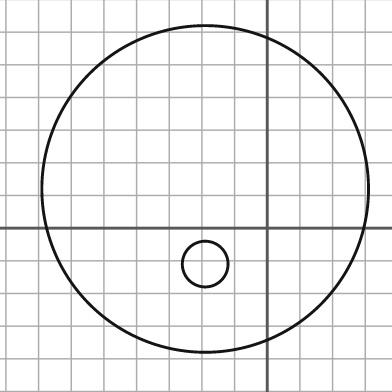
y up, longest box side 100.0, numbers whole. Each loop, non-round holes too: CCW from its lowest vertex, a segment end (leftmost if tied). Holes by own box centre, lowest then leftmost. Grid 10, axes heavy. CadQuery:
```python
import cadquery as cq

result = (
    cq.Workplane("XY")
    .moveTo(-19.0, 12.0)
    .circle(50.0)
    .moveTo(-19.0, -11.0)
    .circle(7.0)
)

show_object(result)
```